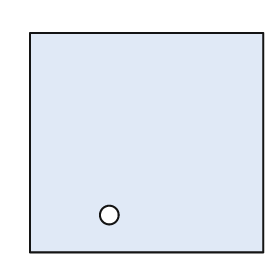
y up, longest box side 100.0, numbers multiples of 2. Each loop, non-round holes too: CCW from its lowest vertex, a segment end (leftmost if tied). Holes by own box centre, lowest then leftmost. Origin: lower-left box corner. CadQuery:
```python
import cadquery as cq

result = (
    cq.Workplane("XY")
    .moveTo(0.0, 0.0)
    .lineTo(100.0, 0.0)
    .lineTo(100.0, 94.0)
    .lineTo(0.0, 94.0)
    .close()
    .moveTo(34.0, 16.0)
    .circle(4.0)
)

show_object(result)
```